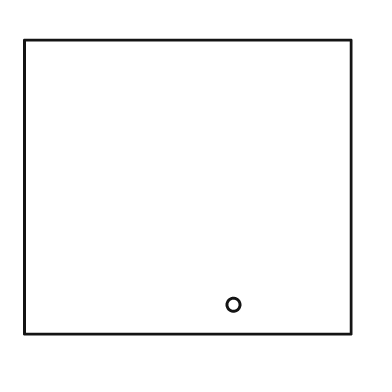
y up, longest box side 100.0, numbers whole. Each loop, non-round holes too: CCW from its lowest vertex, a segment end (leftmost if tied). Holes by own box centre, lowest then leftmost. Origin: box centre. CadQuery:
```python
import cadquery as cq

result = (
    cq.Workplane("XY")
    .moveTo(-50.0, -45.0)
    .lineTo(50.0, -45.0)
    .lineTo(50.0, 45.0)
    .lineTo(-50.0, 45.0)
    .close()
    .moveTo(14.0, -36.0)
    .circle(2.0)
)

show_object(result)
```